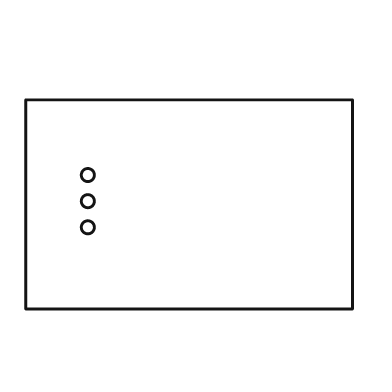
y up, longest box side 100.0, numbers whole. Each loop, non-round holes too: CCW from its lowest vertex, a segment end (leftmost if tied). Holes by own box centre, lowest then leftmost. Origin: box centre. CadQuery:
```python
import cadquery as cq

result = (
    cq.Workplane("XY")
    .moveTo(-50.0, -32.0)
    .lineTo(50.0, -32.0)
    .lineTo(50.0, 32.0)
    .lineTo(-50.0, 32.0)
    .close()
    .moveTo(-31.0, -7.0)
    .circle(2.0)
    .moveTo(-31.0, 1.0)
    .circle(2.0)
    .moveTo(-31.0, 9.0)
    .circle(2.0)
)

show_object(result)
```